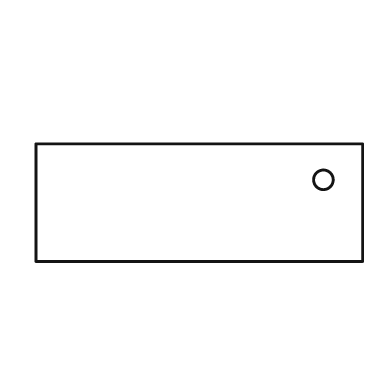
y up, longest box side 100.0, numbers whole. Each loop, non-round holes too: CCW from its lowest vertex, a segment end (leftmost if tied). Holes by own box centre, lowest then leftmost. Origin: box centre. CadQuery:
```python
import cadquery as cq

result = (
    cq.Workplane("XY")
    .moveTo(-50.0, -18.0)
    .lineTo(50.0, -18.0)
    .lineTo(50.0, 18.0)
    .lineTo(-50.0, 18.0)
    .close()
    .moveTo(38.0, 7.0)
    .circle(3.0)
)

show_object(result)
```